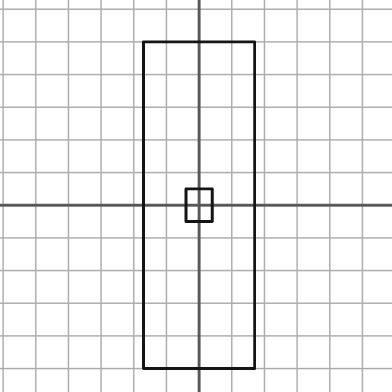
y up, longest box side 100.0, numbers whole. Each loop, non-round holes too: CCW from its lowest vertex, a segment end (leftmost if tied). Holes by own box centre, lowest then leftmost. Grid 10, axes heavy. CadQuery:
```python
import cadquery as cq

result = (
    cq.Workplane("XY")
    .moveTo(-17.0, -50.0)
    .lineTo(17.0, -50.0)
    .lineTo(17.0, 50.0)
    .lineTo(-17.0, 50.0)
    .close()
    .moveTo(-4.0, -5.0)
    .lineTo(4.0, -5.0)
    .lineTo(4.0, 5.0)
    .lineTo(-4.0, 5.0)
    .close()
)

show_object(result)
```